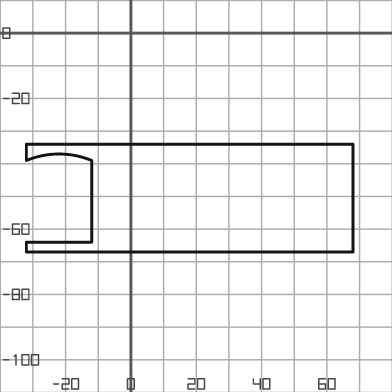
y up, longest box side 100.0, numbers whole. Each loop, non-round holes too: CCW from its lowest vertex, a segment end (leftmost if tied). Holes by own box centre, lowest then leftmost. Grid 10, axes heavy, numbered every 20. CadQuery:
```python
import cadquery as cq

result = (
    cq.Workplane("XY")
    .moveTo(-32.0, -67.0)
    .lineTo(68.0, -67.0)
    .lineTo(68.0, -34.0)
    .lineTo(-32.0, -34.0)
    .lineTo(-32.0, -39.0)
    .threePointArc((-22.0, -37.0), (-12.0, -39.0))
    .lineTo(-12.0, -64.0)
    .lineTo(-32.0, -64.0)
    .close()
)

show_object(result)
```